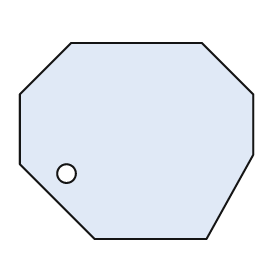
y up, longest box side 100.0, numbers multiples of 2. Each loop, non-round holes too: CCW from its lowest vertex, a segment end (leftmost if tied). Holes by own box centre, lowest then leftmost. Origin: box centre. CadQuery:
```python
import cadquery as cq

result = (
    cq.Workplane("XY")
    .moveTo(-18.0, -42.0)
    .lineTo(30.0, -42.0)
    .lineTo(50.0, -6.0)
    .lineTo(50.0, 20.0)
    .lineTo(28.0, 42.0)
    .lineTo(-28.0, 42.0)
    .lineTo(-50.0, 20.0)
    .lineTo(-50.0, -10.0)
    .close()
    .moveTo(-30.0, -14.0)
    .circle(4.0)
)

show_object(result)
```